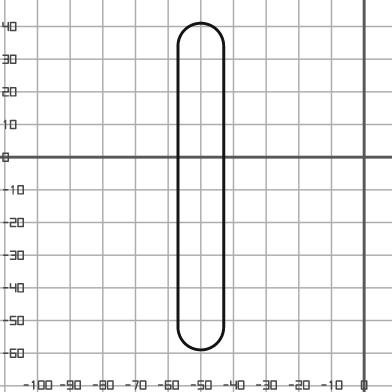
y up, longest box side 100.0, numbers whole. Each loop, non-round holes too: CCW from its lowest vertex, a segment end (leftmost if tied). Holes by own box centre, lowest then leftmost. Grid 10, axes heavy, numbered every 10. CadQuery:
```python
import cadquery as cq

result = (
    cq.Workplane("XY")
    .moveTo(-57.0, -52.0)
    .threePointArc((-50.0, -59.0), (-43.0, -52.0))
    .lineTo(-43.0, 34.0)
    .threePointArc((-50.0, 41.0), (-57.0, 34.0))
    .close()
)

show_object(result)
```